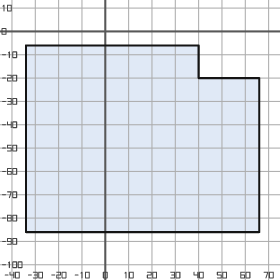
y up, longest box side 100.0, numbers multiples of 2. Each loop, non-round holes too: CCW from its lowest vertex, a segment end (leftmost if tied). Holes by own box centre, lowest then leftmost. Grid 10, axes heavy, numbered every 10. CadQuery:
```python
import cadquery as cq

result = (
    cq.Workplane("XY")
    .moveTo(-34.0, -86.0)
    .lineTo(66.0, -86.0)
    .lineTo(66.0, -20.0)
    .lineTo(40.0, -20.0)
    .lineTo(40.0, -6.0)
    .lineTo(-34.0, -6.0)
    .close()
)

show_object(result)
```